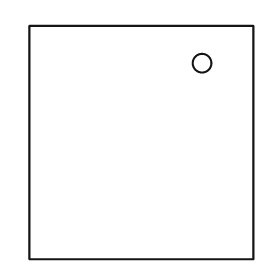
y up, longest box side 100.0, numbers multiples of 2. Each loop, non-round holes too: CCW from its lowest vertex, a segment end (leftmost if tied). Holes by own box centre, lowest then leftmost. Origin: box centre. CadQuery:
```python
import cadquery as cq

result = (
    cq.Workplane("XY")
    .moveTo(-48.0, -50.0)
    .lineTo(48.0, -50.0)
    .lineTo(48.0, 50.0)
    .lineTo(-48.0, 50.0)
    .close()
    .moveTo(26.0, 34.0)
    .circle(4.0)
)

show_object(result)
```